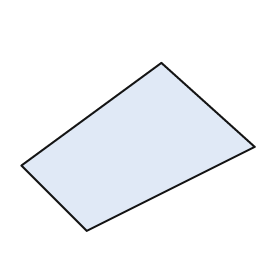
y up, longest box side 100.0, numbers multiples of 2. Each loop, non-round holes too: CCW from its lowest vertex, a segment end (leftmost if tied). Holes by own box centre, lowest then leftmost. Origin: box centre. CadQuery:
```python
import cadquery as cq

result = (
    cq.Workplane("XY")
    .moveTo(-22.0, -36.0)
    .lineTo(50.0, 0.0)
    .lineTo(10.0, 36.0)
    .lineTo(-50.0, -8.0)
    .close()
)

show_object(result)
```